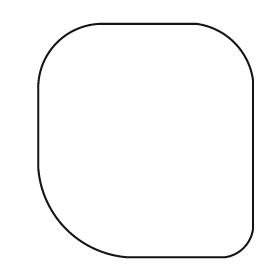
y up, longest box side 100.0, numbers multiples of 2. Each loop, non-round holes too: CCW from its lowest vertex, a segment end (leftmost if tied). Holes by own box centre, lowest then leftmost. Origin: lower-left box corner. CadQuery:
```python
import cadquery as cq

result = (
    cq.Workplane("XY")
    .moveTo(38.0, 0.0)
    .lineTo(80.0, 0.0)
    .threePointArc((88.0, 4.0), (92.0, 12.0))
    .lineTo(92.0, 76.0)
    .threePointArc((84.0, 92.0), (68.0, 100.0))
    .lineTo(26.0, 100.0)
    .threePointArc((8.0, 92.0), (0.0, 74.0))
    .lineTo(0.0, 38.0)
    .threePointArc((12.0, 12.0), (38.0, 0.0))
    .close()
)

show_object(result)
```